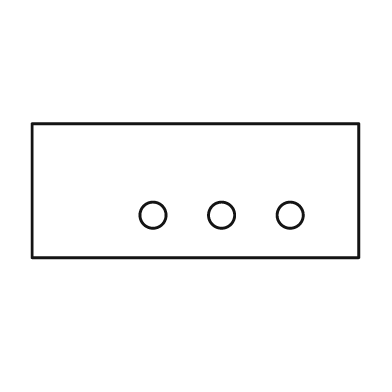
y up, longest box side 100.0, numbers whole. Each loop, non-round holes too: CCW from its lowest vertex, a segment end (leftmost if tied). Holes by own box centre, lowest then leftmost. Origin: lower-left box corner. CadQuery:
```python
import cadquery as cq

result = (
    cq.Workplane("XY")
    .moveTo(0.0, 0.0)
    .lineTo(100.0, 0.0)
    .lineTo(100.0, 41.0)
    .lineTo(0.0, 41.0)
    .close()
    .moveTo(37.0, 13.0)
    .circle(4.0)
    .moveTo(58.0, 13.0)
    .circle(4.0)
    .moveTo(79.0, 13.0)
    .circle(4.0)
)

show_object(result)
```